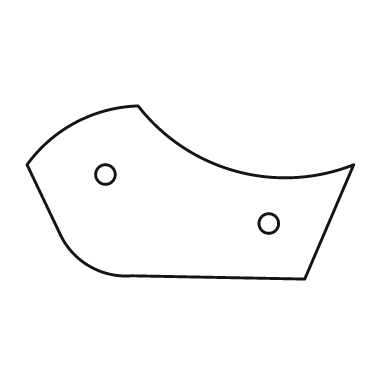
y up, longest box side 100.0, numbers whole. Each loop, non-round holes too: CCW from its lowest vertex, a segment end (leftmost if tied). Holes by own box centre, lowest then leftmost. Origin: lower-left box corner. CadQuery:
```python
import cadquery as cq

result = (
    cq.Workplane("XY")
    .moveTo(85.0, 0.0)
    .lineTo(100.0, 35.0)
    .threePointArc((64.0, 33.0), (34.0, 53.0))
    .threePointArc((15.0, 48.0), (0.0, 35.0))
    .lineTo(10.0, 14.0)
    .threePointArc((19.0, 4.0), (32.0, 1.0))
    .close()
    .moveTo(74.0, 17.0)
    .circle(3.0)
    .moveTo(24.0, 32.0)
    .circle(3.0)
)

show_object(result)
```